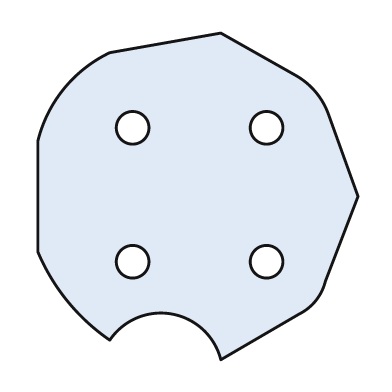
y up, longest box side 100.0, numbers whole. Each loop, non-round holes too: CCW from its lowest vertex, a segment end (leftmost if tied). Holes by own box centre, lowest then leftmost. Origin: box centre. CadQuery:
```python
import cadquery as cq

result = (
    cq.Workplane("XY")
    .moveTo(7.0, -50.0)
    .lineTo(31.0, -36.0)
    .threePointArc((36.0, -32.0), (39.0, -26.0))
    .lineTo(49.0, 0.0)
    .lineTo(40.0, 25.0)
    .threePointArc((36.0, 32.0), (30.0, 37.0))
    .lineTo(7.0, 50.0)
    .lineTo(-27.0, 44.0)
    .threePointArc((-41.0, 33.0), (-49.0, 17.0))
    .lineTo(-49.0, -17.0)
    .threePointArc((-40.0, -32.0), (-27.0, -44.0))
    .threePointArc((-8.0, -36.0), (7.0, -50.0))
    .close()
    .moveTo(-20.0, -20.0)
    .circle(5.0)
    .moveTo(21.0, -20.0)
    .circle(5.0)
    .moveTo(-20.0, 21.0)
    .circle(5.0)
    .moveTo(21.0, 21.0)
    .circle(5.0)
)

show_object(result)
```